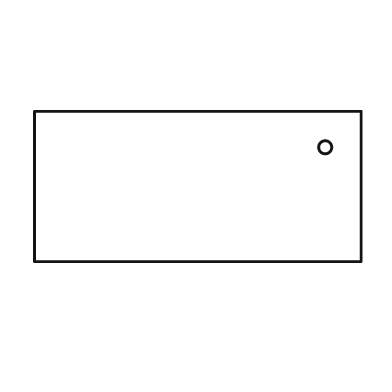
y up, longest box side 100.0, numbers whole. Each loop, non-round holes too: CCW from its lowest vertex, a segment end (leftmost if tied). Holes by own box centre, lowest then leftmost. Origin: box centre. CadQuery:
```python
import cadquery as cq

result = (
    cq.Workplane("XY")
    .moveTo(-50.0, -23.0)
    .lineTo(50.0, -23.0)
    .lineTo(50.0, 23.0)
    .lineTo(-50.0, 23.0)
    .close()
    .moveTo(39.0, 12.0)
    .circle(2.0)
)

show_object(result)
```